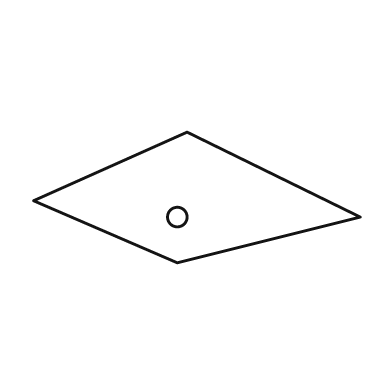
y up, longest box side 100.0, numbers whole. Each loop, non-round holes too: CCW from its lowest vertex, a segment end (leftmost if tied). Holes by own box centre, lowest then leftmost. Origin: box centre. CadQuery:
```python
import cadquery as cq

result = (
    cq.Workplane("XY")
    .moveTo(-6.0, -20.0)
    .lineTo(50.0, -6.0)
    .lineTo(-3.0, 20.0)
    .lineTo(-50.0, -1.0)
    .close()
    .moveTo(-6.0, -6.0)
    .circle(3.0)
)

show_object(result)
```